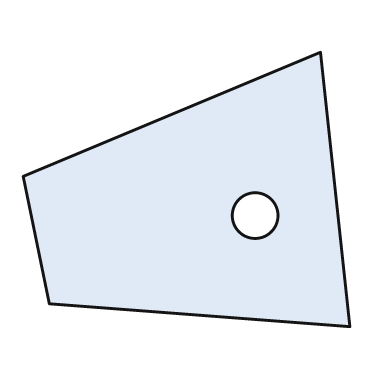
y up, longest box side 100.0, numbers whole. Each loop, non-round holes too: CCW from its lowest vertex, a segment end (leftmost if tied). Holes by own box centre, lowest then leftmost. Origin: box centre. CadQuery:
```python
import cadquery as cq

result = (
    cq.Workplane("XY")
    .moveTo(50.0, -42.0)
    .lineTo(41.0, 42.0)
    .lineTo(-50.0, 4.0)
    .lineTo(-42.0, -35.0)
    .close()
    .moveTo(21.0, -8.0)
    .circle(7.0)
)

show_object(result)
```